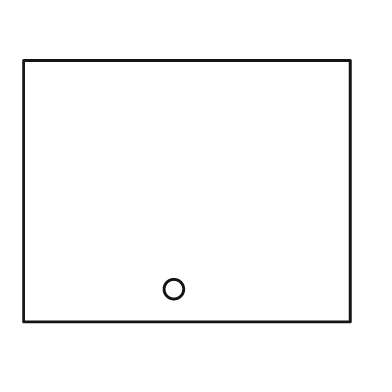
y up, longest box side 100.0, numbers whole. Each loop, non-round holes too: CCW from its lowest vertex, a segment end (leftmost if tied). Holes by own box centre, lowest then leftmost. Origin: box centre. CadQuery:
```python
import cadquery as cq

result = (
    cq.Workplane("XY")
    .moveTo(-50.0, -40.0)
    .lineTo(50.0, -40.0)
    .lineTo(50.0, 40.0)
    .lineTo(-50.0, 40.0)
    .close()
    .moveTo(-4.0, -30.0)
    .circle(3.0)
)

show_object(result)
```